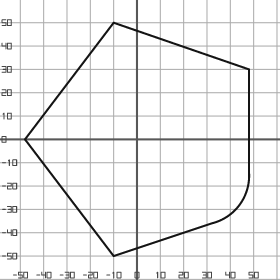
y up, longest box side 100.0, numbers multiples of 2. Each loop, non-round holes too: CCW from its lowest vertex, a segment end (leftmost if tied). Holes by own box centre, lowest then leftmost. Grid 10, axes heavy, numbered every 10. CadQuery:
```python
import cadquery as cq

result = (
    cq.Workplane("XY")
    .moveTo(-10.0, -50.0)
    .lineTo(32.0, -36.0)
    .threePointArc((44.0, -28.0), (48.0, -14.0))
    .lineTo(48.0, 30.0)
    .lineTo(-10.0, 50.0)
    .lineTo(-48.0, 0.0)
    .close()
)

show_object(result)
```